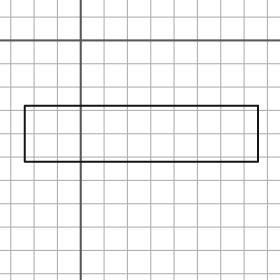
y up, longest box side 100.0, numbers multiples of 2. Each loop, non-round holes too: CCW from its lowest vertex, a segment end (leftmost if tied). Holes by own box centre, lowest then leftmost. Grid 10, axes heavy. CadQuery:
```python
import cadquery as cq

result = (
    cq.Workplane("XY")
    .moveTo(-24.0, -52.0)
    .lineTo(76.0, -52.0)
    .lineTo(76.0, -28.0)
    .lineTo(-24.0, -28.0)
    .close()
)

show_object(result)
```